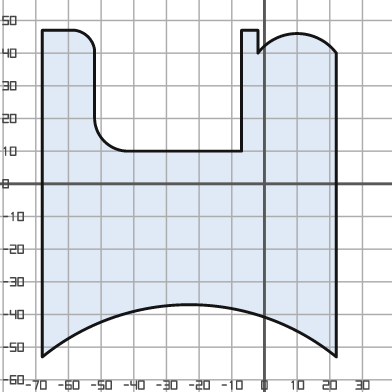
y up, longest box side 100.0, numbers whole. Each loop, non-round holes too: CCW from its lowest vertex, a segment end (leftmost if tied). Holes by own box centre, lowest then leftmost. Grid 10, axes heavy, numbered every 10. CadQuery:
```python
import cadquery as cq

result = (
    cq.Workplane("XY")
    .moveTo(-68.0, -53.0)
    .threePointArc((-23.0, -37.0), (22.0, -53.0))
    .lineTo(22.0, 40.0)
    .threePointArc((10.0, 46.0), (-2.0, 40.0))
    .lineTo(-2.0, 47.0)
    .lineTo(-7.0, 47.0)
    .lineTo(-7.0, 10.0)
    .lineTo(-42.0, 10.0)
    .threePointArc((-49.0, 13.0), (-52.0, 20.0))
    .lineTo(-52.0, 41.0)
    .threePointArc((-54.0, 45.0), (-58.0, 47.0))
    .lineTo(-68.0, 47.0)
    .close()
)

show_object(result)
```